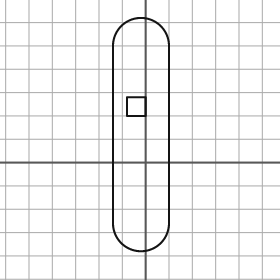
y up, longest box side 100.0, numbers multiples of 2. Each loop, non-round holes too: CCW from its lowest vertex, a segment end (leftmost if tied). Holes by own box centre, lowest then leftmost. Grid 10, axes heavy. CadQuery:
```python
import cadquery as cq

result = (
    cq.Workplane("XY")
    .moveTo(-14.0, -26.0)
    .threePointArc((-2.0, -38.0), (10.0, -26.0))
    .lineTo(10.0, 50.0)
    .threePointArc((-2.0, 62.0), (-14.0, 50.0))
    .close()
    .moveTo(-8.0, 20.0)
    .lineTo(0.0, 20.0)
    .lineTo(0.0, 28.0)
    .lineTo(-8.0, 28.0)
    .close()
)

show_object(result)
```